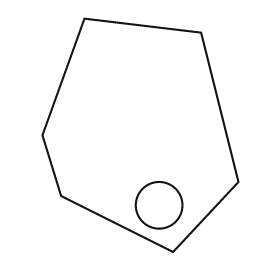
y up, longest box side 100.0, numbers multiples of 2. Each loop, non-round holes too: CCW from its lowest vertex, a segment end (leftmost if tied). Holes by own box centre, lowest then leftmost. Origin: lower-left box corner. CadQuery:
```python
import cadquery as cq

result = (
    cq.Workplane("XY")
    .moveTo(56.0, 0.0)
    .lineTo(84.0, 30.0)
    .lineTo(68.0, 94.0)
    .lineTo(18.0, 100.0)
    .lineTo(0.0, 50.0)
    .lineTo(8.0, 24.0)
    .close()
    .moveTo(50.0, 20.0)
    .circle(10.0)
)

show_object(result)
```